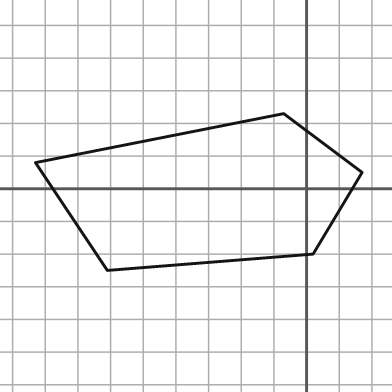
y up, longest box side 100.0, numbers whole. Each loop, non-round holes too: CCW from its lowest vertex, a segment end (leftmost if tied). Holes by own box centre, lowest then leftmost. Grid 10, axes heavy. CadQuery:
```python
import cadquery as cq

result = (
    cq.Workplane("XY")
    .moveTo(-61.0, -25.0)
    .lineTo(2.0, -20.0)
    .lineTo(17.0, 5.0)
    .lineTo(-7.0, 23.0)
    .lineTo(-83.0, 8.0)
    .close()
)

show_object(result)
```